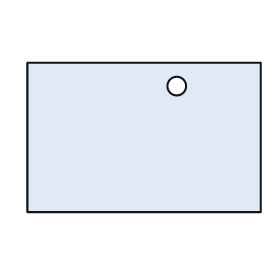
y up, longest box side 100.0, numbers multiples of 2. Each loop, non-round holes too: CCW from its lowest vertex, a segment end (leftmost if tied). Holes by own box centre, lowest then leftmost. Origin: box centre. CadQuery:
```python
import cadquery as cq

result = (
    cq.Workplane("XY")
    .moveTo(-50.0, -32.0)
    .lineTo(50.0, -32.0)
    .lineTo(50.0, 32.0)
    .lineTo(-50.0, 32.0)
    .close()
    .moveTo(14.0, 22.0)
    .circle(4.0)
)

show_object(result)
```